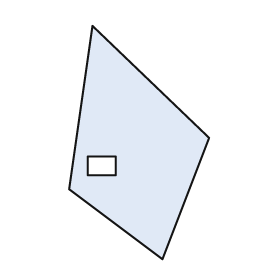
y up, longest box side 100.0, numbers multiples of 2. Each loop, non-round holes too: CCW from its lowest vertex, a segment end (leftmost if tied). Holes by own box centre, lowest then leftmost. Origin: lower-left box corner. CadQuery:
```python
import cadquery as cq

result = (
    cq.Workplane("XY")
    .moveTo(40.0, 0.0)
    .lineTo(60.0, 52.0)
    .lineTo(10.0, 100.0)
    .lineTo(0.0, 30.0)
    .close()
    .moveTo(8.0, 36.0)
    .lineTo(20.0, 36.0)
    .lineTo(20.0, 44.0)
    .lineTo(8.0, 44.0)
    .close()
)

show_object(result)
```